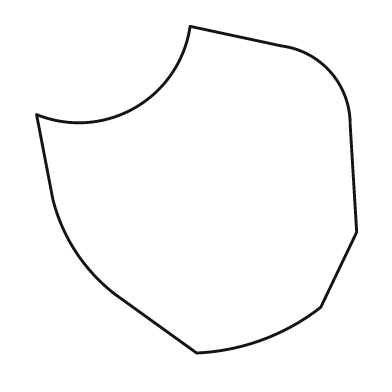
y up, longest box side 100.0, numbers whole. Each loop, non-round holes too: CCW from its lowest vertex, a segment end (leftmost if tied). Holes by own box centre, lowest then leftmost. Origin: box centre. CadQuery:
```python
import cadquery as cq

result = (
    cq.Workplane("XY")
    .moveTo(0.0, -50.0)
    .threePointArc((20.0, -46.0), (38.0, -36.0))
    .lineTo(49.0, -13.0)
    .lineTo(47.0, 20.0)
    .threePointArc((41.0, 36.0), (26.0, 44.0))
    .lineTo(-2.0, 50.0)
    .threePointArc((-19.0, 25.0), (-49.0, 23.0))
    .lineTo(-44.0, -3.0)
    .threePointArc((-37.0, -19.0), (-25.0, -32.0))
    .close()
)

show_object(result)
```